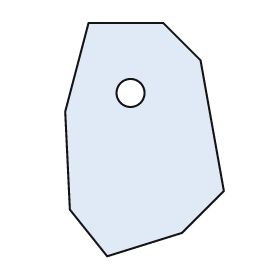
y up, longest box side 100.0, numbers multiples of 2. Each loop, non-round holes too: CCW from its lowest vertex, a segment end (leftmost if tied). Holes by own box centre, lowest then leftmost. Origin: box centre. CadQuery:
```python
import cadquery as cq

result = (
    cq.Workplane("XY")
    .moveTo(-16.0, -50.0)
    .lineTo(16.0, -40.0)
    .lineTo(34.0, -22.0)
    .lineTo(24.0, 34.0)
    .lineTo(8.0, 50.0)
    .lineTo(-24.0, 50.0)
    .lineTo(-34.0, 12.0)
    .lineTo(-32.0, -30.0)
    .close()
    .moveTo(-6.0, 20.0)
    .circle(6.0)
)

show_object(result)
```